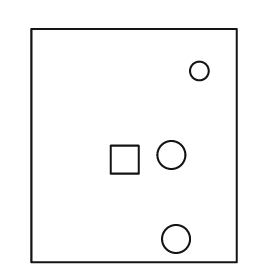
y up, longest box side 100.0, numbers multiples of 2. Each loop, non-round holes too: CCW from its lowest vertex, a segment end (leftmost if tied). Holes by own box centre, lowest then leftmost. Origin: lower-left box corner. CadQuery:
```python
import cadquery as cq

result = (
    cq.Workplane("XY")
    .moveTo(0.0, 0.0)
    .lineTo(88.0, 0.0)
    .lineTo(88.0, 100.0)
    .lineTo(0.0, 100.0)
    .close()
    .moveTo(62.0, 10.0)
    .circle(6.0)
    .moveTo(34.0, 38.0)
    .lineTo(46.0, 38.0)
    .lineTo(46.0, 50.0)
    .lineTo(34.0, 50.0)
    .close()
    .moveTo(60.0, 46.0)
    .circle(6.0)
    .moveTo(72.0, 82.0)
    .circle(4.0)
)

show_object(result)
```